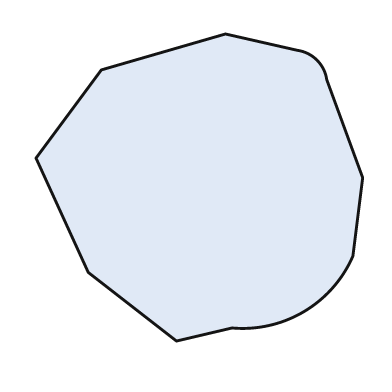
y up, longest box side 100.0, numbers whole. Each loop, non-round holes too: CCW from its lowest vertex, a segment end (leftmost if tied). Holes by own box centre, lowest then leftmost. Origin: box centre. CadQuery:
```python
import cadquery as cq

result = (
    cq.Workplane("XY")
    .moveTo(-7.0, -47.0)
    .lineTo(10.0, -43.0)
    .threePointArc((32.0, -38.0), (47.0, -21.0))
    .lineTo(50.0, 3.0)
    .lineTo(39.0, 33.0)
    .threePointArc((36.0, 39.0), (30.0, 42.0))
    .lineTo(8.0, 47.0)
    .lineTo(-30.0, 36.0)
    .lineTo(-50.0, 9.0)
    .lineTo(-34.0, -26.0)
    .close()
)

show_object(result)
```